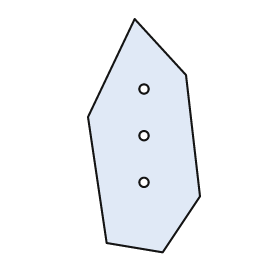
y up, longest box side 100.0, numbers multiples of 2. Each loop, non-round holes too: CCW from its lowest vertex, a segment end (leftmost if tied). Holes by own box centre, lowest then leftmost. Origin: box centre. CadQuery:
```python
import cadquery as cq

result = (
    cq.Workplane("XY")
    .moveTo(8.0, -50.0)
    .lineTo(24.0, -26.0)
    .lineTo(18.0, 26.0)
    .lineTo(-4.0, 50.0)
    .lineTo(-24.0, 8.0)
    .lineTo(-16.0, -46.0)
    .close()
    .moveTo(0.0, -20.0)
    .circle(2.0)
    .moveTo(0.0, 0.0)
    .circle(2.0)
    .moveTo(0.0, 20.0)
    .circle(2.0)
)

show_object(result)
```